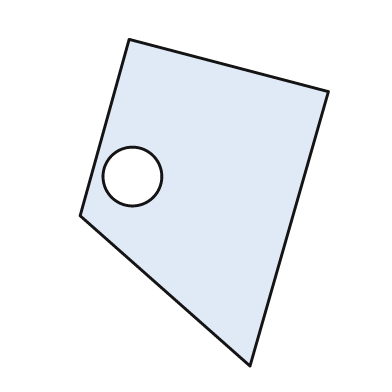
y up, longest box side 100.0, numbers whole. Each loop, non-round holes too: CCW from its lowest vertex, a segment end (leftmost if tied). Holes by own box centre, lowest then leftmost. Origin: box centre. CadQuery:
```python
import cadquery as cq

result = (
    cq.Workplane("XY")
    .moveTo(14.0, -50.0)
    .lineTo(38.0, 34.0)
    .lineTo(-23.0, 50.0)
    .lineTo(-38.0, -4.0)
    .close()
    .moveTo(-22.0, 8.0)
    .circle(9.0)
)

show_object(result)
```